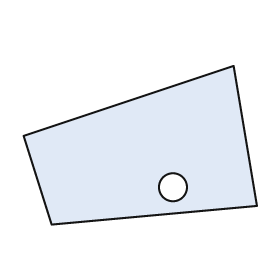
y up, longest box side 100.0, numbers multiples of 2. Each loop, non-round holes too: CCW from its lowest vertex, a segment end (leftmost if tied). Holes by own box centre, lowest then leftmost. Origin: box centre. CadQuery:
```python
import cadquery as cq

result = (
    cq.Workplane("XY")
    .moveTo(-38.0, -34.0)
    .lineTo(50.0, -26.0)
    .lineTo(40.0, 34.0)
    .lineTo(-50.0, 4.0)
    .close()
    .moveTo(14.0, -18.0)
    .circle(6.0)
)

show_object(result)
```